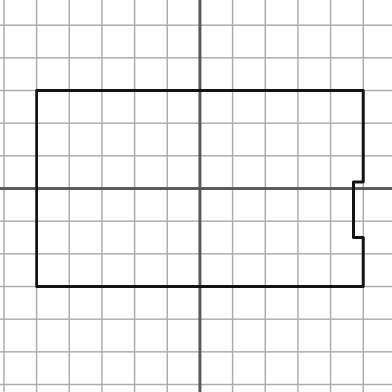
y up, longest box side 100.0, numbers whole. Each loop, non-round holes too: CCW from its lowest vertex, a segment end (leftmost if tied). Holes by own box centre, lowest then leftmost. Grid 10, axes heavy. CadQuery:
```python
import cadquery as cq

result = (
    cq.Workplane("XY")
    .moveTo(-50.0, -30.0)
    .lineTo(50.0, -30.0)
    .lineTo(50.0, -15.0)
    .lineTo(47.0, -15.0)
    .lineTo(47.0, 2.0)
    .lineTo(50.0, 2.0)
    .lineTo(50.0, 30.0)
    .lineTo(-50.0, 30.0)
    .close()
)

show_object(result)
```